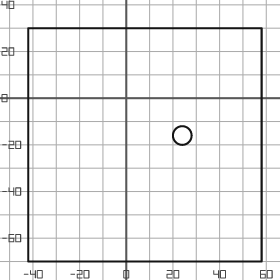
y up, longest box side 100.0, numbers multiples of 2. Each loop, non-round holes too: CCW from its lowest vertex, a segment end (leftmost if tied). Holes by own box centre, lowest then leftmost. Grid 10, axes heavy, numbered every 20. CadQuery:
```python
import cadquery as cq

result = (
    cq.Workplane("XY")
    .moveTo(-42.0, -70.0)
    .lineTo(58.0, -70.0)
    .lineTo(58.0, 30.0)
    .lineTo(-42.0, 30.0)
    .close()
    .moveTo(24.0, -16.0)
    .circle(4.0)
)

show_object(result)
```